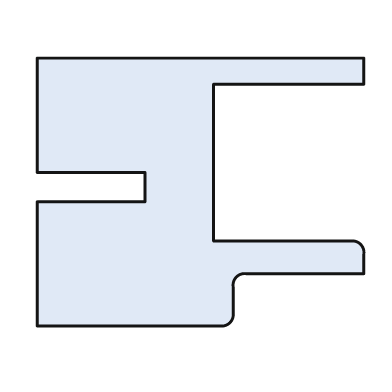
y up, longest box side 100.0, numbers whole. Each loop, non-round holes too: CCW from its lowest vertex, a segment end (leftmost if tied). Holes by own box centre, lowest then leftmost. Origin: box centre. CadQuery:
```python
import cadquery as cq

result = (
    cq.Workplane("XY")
    .moveTo(-50.0, -41.0)
    .lineTo(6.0, -41.0)
    .threePointArc((9.0, -40.0), (10.0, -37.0))
    .lineTo(10.0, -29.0)
    .threePointArc((11.0, -26.0), (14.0, -25.0))
    .lineTo(50.0, -25.0)
    .lineTo(50.0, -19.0)
    .threePointArc((49.0, -16.0), (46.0, -15.0))
    .lineTo(4.0, -15.0)
    .lineTo(4.0, 33.0)
    .lineTo(50.0, 33.0)
    .lineTo(50.0, 41.0)
    .lineTo(-50.0, 41.0)
    .lineTo(-50.0, 6.0)
    .lineTo(-17.0, 6.0)
    .lineTo(-17.0, -3.0)
    .lineTo(-50.0, -3.0)
    .close()
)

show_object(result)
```